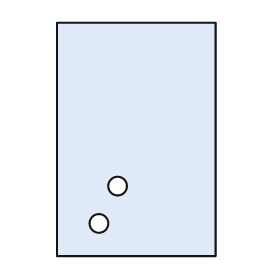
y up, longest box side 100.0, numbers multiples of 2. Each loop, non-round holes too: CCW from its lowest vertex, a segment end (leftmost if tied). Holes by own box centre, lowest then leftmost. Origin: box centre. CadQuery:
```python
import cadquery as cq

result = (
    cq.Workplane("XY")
    .moveTo(-34.0, -50.0)
    .lineTo(34.0, -50.0)
    .lineTo(34.0, 50.0)
    .lineTo(-34.0, 50.0)
    .close()
    .moveTo(-16.0, -36.0)
    .circle(4.0)
    .moveTo(-8.0, -20.0)
    .circle(4.0)
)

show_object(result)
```